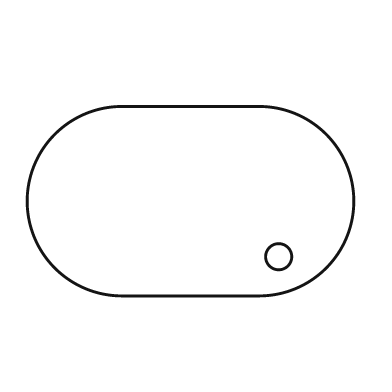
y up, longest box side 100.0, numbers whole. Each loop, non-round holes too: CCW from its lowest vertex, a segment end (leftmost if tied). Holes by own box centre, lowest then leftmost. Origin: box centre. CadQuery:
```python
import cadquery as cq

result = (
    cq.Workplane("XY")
    .moveTo(-21.0, -29.0)
    .lineTo(21.0, -29.0)
    .threePointArc((50.0, 0.0), (21.0, 29.0))
    .lineTo(-21.0, 29.0)
    .threePointArc((-50.0, 0.0), (-21.0, -29.0))
    .close()
    .moveTo(27.0, -17.0)
    .circle(4.0)
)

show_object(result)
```